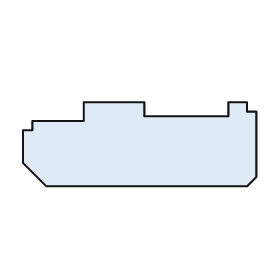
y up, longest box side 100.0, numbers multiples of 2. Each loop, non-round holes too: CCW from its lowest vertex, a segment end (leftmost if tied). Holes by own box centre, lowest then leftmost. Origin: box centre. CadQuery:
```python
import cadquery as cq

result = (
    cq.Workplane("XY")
    .moveTo(-40.0, -18.0)
    .lineTo(46.0, -18.0)
    .lineTo(50.0, -14.0)
    .lineTo(50.0, 14.0)
    .lineTo(46.0, 14.0)
    .lineTo(46.0, 18.0)
    .lineTo(38.0, 18.0)
    .lineTo(38.0, 12.0)
    .lineTo(2.0, 12.0)
    .lineTo(2.0, 18.0)
    .lineTo(-24.0, 18.0)
    .lineTo(-24.0, 10.0)
    .lineTo(-46.0, 10.0)
    .lineTo(-46.0, 6.0)
    .lineTo(-50.0, 6.0)
    .lineTo(-50.0, -8.0)
    .close()
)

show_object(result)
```